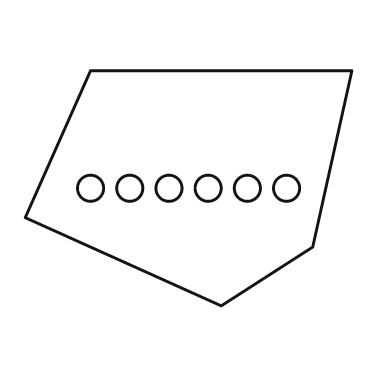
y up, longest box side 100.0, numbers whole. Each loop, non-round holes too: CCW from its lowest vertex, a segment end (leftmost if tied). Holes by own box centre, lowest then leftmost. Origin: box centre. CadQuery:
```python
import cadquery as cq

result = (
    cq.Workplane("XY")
    .moveTo(10.0, -36.0)
    .lineTo(38.0, -18.0)
    .lineTo(50.0, 36.0)
    .lineTo(-30.0, 36.0)
    .lineTo(-50.0, -9.0)
    .close()
    .moveTo(-30.0, 0.0)
    .circle(4.0)
    .moveTo(-18.0, 0.0)
    .circle(4.0)
    .moveTo(-6.0, 0.0)
    .circle(4.0)
    .moveTo(6.0, 0.0)
    .circle(4.0)
    .moveTo(18.0, 0.0)
    .circle(4.0)
    .moveTo(30.0, 0.0)
    .circle(4.0)
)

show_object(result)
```